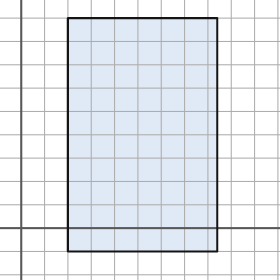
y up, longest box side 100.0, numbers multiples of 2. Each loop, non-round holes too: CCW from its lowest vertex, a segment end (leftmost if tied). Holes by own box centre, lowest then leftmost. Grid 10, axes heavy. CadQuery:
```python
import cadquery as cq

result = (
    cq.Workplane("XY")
    .moveTo(20.0, -10.0)
    .lineTo(84.0, -10.0)
    .lineTo(84.0, 90.0)
    .lineTo(20.0, 90.0)
    .close()
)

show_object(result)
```